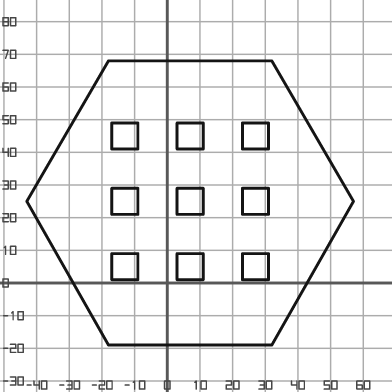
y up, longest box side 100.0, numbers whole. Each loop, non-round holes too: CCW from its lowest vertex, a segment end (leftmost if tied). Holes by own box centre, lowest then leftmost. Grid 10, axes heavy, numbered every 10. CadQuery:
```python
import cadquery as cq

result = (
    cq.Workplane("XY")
    .moveTo(-18.0, -19.0)
    .lineTo(32.0, -19.0)
    .lineTo(57.0, 25.0)
    .lineTo(32.0, 68.0)
    .lineTo(-18.0, 68.0)
    .lineTo(-43.0, 25.0)
    .close()
    .moveTo(-17.0, 1.0)
    .lineTo(-9.0, 1.0)
    .lineTo(-9.0, 9.0)
    .lineTo(-17.0, 9.0)
    .close()
    .moveTo(3.0, 1.0)
    .lineTo(11.0, 1.0)
    .lineTo(11.0, 9.0)
    .lineTo(3.0, 9.0)
    .close()
    .moveTo(23.0, 1.0)
    .lineTo(31.0, 1.0)
    .lineTo(31.0, 9.0)
    .lineTo(23.0, 9.0)
    .close()
    .moveTo(-17.0, 21.0)
    .lineTo(-9.0, 21.0)
    .lineTo(-9.0, 29.0)
    .lineTo(-17.0, 29.0)
    .close()
    .moveTo(3.0, 21.0)
    .lineTo(11.0, 21.0)
    .lineTo(11.0, 29.0)
    .lineTo(3.0, 29.0)
    .close()
    .moveTo(23.0, 21.0)
    .lineTo(31.0, 21.0)
    .lineTo(31.0, 29.0)
    .lineTo(23.0, 29.0)
    .close()
    .moveTo(-17.0, 41.0)
    .lineTo(-9.0, 41.0)
    .lineTo(-9.0, 49.0)
    .lineTo(-17.0, 49.0)
    .close()
    .moveTo(3.0, 41.0)
    .lineTo(11.0, 41.0)
    .lineTo(11.0, 49.0)
    .lineTo(3.0, 49.0)
    .close()
    .moveTo(23.0, 41.0)
    .lineTo(31.0, 41.0)
    .lineTo(31.0, 49.0)
    .lineTo(23.0, 49.0)
    .close()
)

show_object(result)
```